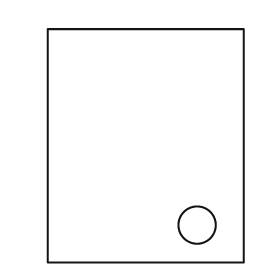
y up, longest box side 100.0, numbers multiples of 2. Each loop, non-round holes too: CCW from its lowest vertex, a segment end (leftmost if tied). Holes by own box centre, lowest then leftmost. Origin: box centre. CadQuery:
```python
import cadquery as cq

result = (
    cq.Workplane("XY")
    .moveTo(-42.0, -50.0)
    .lineTo(42.0, -50.0)
    .lineTo(42.0, 50.0)
    .lineTo(-42.0, 50.0)
    .close()
    .moveTo(22.0, -34.0)
    .circle(8.0)
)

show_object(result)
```